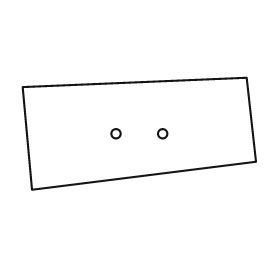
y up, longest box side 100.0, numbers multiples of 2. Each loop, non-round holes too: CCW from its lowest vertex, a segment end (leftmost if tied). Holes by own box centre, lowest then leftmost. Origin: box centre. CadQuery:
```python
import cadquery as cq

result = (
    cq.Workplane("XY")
    .moveTo(-46.0, -24.0)
    .lineTo(50.0, -12.0)
    .lineTo(46.0, 24.0)
    .lineTo(-50.0, 20.0)
    .close()
    .moveTo(-10.0, 0.0)
    .circle(2.0)
    .moveTo(10.0, 0.0)
    .circle(2.0)
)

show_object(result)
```